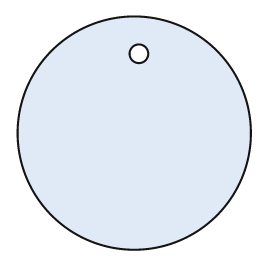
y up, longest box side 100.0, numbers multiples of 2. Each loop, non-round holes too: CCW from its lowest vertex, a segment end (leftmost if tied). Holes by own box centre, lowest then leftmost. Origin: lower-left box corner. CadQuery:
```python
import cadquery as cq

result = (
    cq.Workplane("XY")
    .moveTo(50.0, 50.0)
    .circle(50.0)
    .moveTo(52.0, 84.0)
    .circle(4.0)
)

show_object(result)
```